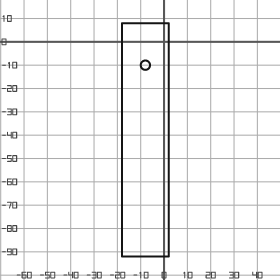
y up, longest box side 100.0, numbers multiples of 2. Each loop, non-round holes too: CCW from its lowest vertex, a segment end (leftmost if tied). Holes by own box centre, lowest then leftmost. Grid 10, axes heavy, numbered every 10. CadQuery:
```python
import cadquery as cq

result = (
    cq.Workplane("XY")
    .moveTo(-18.0, -92.0)
    .lineTo(2.0, -92.0)
    .lineTo(2.0, 8.0)
    .lineTo(-18.0, 8.0)
    .close()
    .moveTo(-8.0, -10.0)
    .circle(2.0)
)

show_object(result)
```